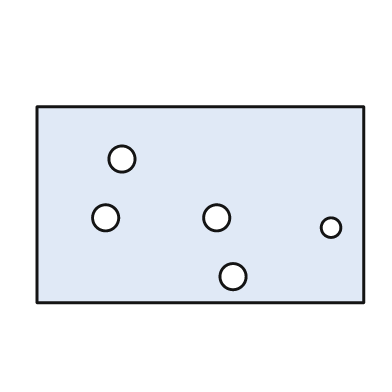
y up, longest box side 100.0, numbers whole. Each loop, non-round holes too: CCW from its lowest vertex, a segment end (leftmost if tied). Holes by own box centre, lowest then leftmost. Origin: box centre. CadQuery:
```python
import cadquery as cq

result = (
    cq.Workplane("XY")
    .moveTo(-50.0, -30.0)
    .lineTo(50.0, -30.0)
    .lineTo(50.0, 30.0)
    .lineTo(-50.0, 30.0)
    .close()
    .moveTo(10.0, -22.0)
    .circle(4.0)
    .moveTo(40.0, -7.0)
    .circle(3.0)
    .moveTo(-29.0, -4.0)
    .circle(4.0)
    .moveTo(5.0, -4.0)
    .circle(4.0)
    .moveTo(-24.0, 14.0)
    .circle(4.0)
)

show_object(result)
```